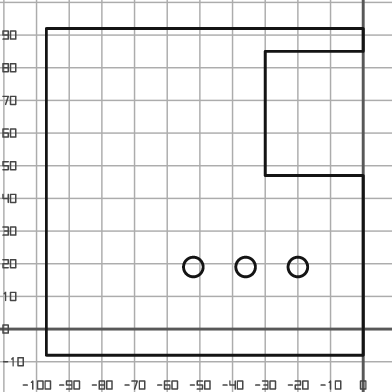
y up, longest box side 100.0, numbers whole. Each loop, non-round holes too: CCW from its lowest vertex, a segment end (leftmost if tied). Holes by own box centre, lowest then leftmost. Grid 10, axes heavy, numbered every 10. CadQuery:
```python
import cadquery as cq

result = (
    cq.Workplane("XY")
    .moveTo(-97.0, -8.0)
    .lineTo(0.0, -8.0)
    .lineTo(0.0, 47.0)
    .lineTo(-30.0, 47.0)
    .lineTo(-30.0, 85.0)
    .lineTo(0.0, 85.0)
    .lineTo(0.0, 92.0)
    .lineTo(-97.0, 92.0)
    .close()
    .moveTo(-52.0, 19.0)
    .circle(3.0)
    .moveTo(-36.0, 19.0)
    .circle(3.0)
    .moveTo(-20.0, 19.0)
    .circle(3.0)
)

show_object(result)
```